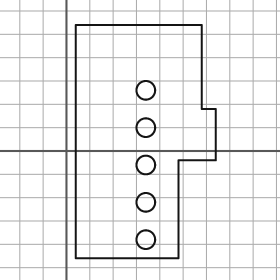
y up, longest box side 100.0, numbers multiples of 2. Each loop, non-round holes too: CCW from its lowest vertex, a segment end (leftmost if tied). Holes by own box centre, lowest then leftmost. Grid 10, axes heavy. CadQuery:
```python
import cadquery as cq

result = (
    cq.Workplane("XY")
    .moveTo(4.0, -46.0)
    .lineTo(48.0, -46.0)
    .lineTo(48.0, -4.0)
    .lineTo(64.0, -4.0)
    .lineTo(64.0, 18.0)
    .lineTo(58.0, 18.0)
    .lineTo(58.0, 54.0)
    .lineTo(4.0, 54.0)
    .close()
    .moveTo(34.0, -38.0)
    .circle(4.0)
    .moveTo(34.0, -22.0)
    .circle(4.0)
    .moveTo(34.0, -6.0)
    .circle(4.0)
    .moveTo(34.0, 10.0)
    .circle(4.0)
    .moveTo(34.0, 26.0)
    .circle(4.0)
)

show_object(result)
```